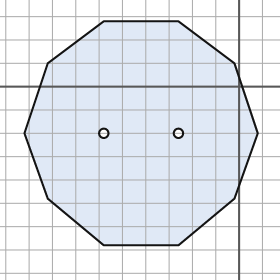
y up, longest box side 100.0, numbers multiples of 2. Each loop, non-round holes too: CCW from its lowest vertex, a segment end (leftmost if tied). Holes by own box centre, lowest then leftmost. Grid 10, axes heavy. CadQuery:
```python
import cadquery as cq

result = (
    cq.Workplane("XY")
    .moveTo(-58.0, -68.0)
    .lineTo(-26.0, -68.0)
    .lineTo(-2.0, -48.0)
    .lineTo(8.0, -20.0)
    .lineTo(-2.0, 10.0)
    .lineTo(-26.0, 28.0)
    .lineTo(-58.0, 28.0)
    .lineTo(-82.0, 10.0)
    .lineTo(-92.0, -20.0)
    .lineTo(-82.0, -48.0)
    .close()
    .moveTo(-58.0, -20.0)
    .circle(2.0)
    .moveTo(-26.0, -20.0)
    .circle(2.0)
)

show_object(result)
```